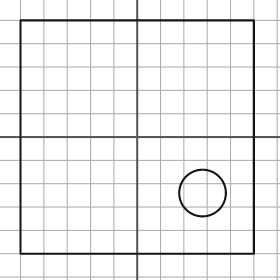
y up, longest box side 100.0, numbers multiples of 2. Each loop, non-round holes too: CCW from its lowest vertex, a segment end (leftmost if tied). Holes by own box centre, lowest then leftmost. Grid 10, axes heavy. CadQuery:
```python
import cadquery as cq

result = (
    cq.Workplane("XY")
    .moveTo(-50.0, -50.0)
    .lineTo(50.0, -50.0)
    .lineTo(50.0, 50.0)
    .lineTo(-50.0, 50.0)
    .close()
    .moveTo(28.0, -24.0)
    .circle(10.0)
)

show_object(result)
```